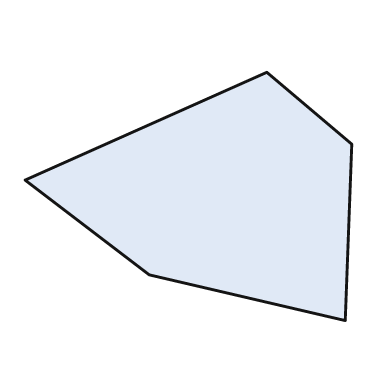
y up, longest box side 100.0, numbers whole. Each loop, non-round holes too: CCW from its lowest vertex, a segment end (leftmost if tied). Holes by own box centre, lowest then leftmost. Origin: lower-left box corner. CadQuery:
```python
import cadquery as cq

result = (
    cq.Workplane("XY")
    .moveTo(98.0, 0.0)
    .lineTo(100.0, 54.0)
    .lineTo(74.0, 76.0)
    .lineTo(0.0, 43.0)
    .lineTo(38.0, 14.0)
    .close()
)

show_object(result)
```